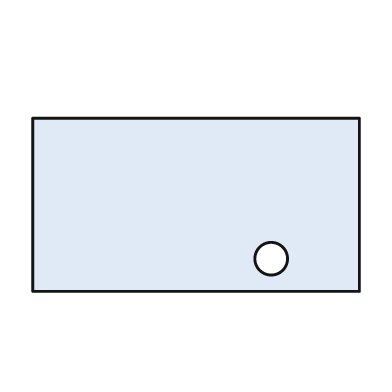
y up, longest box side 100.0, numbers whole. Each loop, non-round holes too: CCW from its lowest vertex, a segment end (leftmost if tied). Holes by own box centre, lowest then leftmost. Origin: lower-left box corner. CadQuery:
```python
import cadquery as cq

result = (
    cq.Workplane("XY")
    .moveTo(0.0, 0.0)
    .lineTo(100.0, 0.0)
    .lineTo(100.0, 53.0)
    .lineTo(0.0, 53.0)
    .close()
    .moveTo(73.0, 10.0)
    .circle(5.0)
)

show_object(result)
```